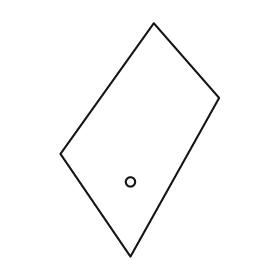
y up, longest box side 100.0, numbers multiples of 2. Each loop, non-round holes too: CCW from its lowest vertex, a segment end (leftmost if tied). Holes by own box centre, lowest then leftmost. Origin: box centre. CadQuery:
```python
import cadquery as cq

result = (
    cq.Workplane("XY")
    .moveTo(-4.0, -50.0)
    .lineTo(34.0, 18.0)
    .lineTo(6.0, 50.0)
    .lineTo(-34.0, -6.0)
    .close()
    .moveTo(-4.0, -18.0)
    .circle(2.0)
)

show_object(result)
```